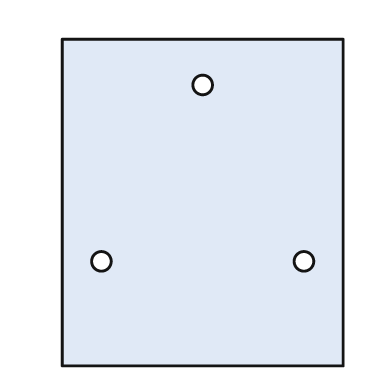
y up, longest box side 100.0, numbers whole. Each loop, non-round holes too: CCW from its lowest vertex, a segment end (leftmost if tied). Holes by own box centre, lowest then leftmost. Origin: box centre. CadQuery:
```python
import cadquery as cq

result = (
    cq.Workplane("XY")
    .moveTo(-43.0, -50.0)
    .lineTo(43.0, -50.0)
    .lineTo(43.0, 50.0)
    .lineTo(-43.0, 50.0)
    .close()
    .moveTo(-31.0, -18.0)
    .circle(3.0)
    .moveTo(31.0, -18.0)
    .circle(3.0)
    .moveTo(0.0, 36.0)
    .circle(3.0)
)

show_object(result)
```